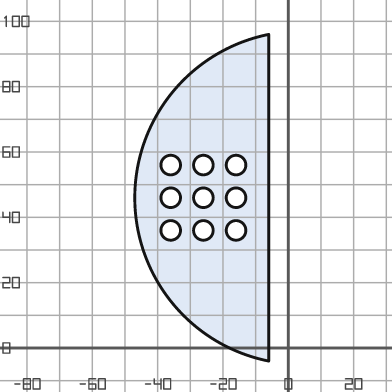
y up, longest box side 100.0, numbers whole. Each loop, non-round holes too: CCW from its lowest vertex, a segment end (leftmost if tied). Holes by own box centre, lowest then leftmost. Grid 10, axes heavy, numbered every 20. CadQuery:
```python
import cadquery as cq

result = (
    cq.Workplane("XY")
    .moveTo(-6.0, -4.0)
    .lineTo(-6.0, 96.0)
    .threePointArc((-47.0, 46.0), (-6.0, -4.0))
    .close()
    .moveTo(-36.0, 36.0)
    .circle(3.0)
    .moveTo(-26.0, 36.0)
    .circle(3.0)
    .moveTo(-16.0, 36.0)
    .circle(3.0)
    .moveTo(-36.0, 46.0)
    .circle(3.0)
    .moveTo(-26.0, 46.0)
    .circle(3.0)
    .moveTo(-16.0, 46.0)
    .circle(3.0)
    .moveTo(-36.0, 56.0)
    .circle(3.0)
    .moveTo(-26.0, 56.0)
    .circle(3.0)
    .moveTo(-16.0, 56.0)
    .circle(3.0)
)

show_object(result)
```